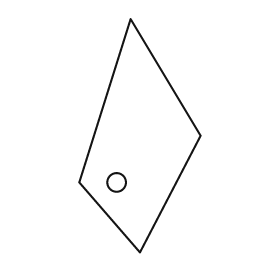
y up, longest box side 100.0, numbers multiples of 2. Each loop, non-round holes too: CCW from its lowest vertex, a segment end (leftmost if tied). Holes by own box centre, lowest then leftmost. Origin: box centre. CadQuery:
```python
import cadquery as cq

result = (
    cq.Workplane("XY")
    .moveTo(0.0, -50.0)
    .lineTo(26.0, 0.0)
    .lineTo(-4.0, 50.0)
    .lineTo(-26.0, -20.0)
    .close()
    .moveTo(-10.0, -20.0)
    .circle(4.0)
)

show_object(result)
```